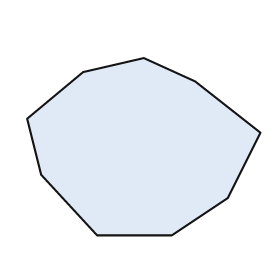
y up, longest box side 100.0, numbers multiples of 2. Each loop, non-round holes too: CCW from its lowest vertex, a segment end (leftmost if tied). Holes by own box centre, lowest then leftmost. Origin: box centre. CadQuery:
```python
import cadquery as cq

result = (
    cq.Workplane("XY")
    .moveTo(-20.0, -38.0)
    .lineTo(12.0, -38.0)
    .lineTo(36.0, -22.0)
    .lineTo(50.0, 6.0)
    .lineTo(22.0, 28.0)
    .lineTo(0.0, 38.0)
    .lineTo(-26.0, 32.0)
    .lineTo(-50.0, 12.0)
    .lineTo(-44.0, -12.0)
    .close()
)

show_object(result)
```